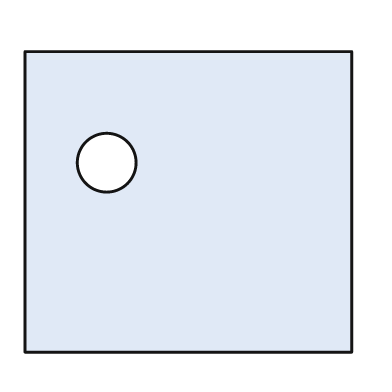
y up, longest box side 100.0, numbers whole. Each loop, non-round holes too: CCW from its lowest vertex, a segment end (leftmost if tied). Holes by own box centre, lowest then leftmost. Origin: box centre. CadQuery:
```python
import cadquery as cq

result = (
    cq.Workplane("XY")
    .moveTo(-50.0, -46.0)
    .lineTo(50.0, -46.0)
    .lineTo(50.0, 46.0)
    .lineTo(-50.0, 46.0)
    .close()
    .moveTo(-25.0, 12.0)
    .circle(9.0)
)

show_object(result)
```